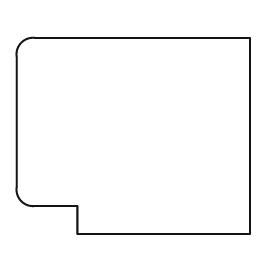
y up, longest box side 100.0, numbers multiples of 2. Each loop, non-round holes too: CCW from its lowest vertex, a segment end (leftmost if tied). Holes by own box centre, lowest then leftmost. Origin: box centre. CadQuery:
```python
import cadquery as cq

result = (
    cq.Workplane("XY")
    .moveTo(-24.0, -42.0)
    .lineTo(50.0, -42.0)
    .lineTo(50.0, 42.0)
    .lineTo(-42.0, 42.0)
    .threePointArc((-48.0, 40.0), (-50.0, 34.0))
    .lineTo(-50.0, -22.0)
    .threePointArc((-48.0, -28.0), (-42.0, -30.0))
    .lineTo(-24.0, -30.0)
    .close()
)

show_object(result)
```